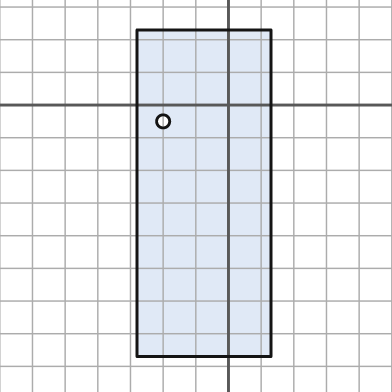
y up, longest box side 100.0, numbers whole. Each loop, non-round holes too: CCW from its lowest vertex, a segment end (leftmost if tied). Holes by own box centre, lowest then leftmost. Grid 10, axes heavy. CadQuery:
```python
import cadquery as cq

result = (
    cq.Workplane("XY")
    .moveTo(-28.0, -77.0)
    .lineTo(13.0, -77.0)
    .lineTo(13.0, 23.0)
    .lineTo(-28.0, 23.0)
    .close()
    .moveTo(-20.0, -5.0)
    .circle(2.0)
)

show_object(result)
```